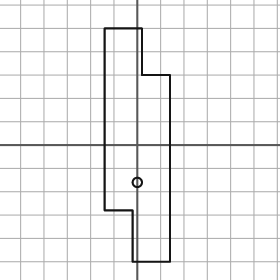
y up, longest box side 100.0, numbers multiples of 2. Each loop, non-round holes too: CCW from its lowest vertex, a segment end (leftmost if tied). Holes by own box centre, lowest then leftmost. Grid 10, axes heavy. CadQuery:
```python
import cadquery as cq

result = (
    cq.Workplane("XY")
    .moveTo(-2.0, -50.0)
    .lineTo(14.0, -50.0)
    .lineTo(14.0, 30.0)
    .lineTo(2.0, 30.0)
    .lineTo(2.0, 50.0)
    .lineTo(-14.0, 50.0)
    .lineTo(-14.0, -28.0)
    .lineTo(-2.0, -28.0)
    .close()
    .moveTo(0.0, -16.0)
    .circle(2.0)
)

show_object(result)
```